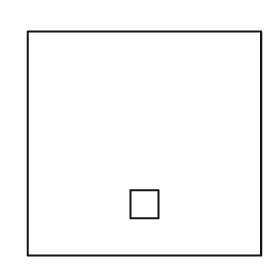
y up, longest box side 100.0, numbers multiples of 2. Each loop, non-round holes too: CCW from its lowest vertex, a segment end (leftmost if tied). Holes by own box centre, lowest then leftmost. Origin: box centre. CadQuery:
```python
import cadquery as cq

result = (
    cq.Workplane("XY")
    .moveTo(-50.0, -48.0)
    .lineTo(50.0, -48.0)
    .lineTo(50.0, 48.0)
    .lineTo(-50.0, 48.0)
    .close()
    .moveTo(-6.0, -32.0)
    .lineTo(6.0, -32.0)
    .lineTo(6.0, -20.0)
    .lineTo(-6.0, -20.0)
    .close()
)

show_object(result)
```